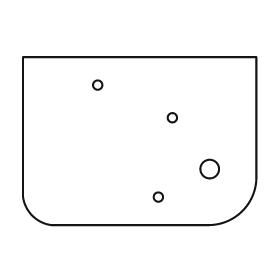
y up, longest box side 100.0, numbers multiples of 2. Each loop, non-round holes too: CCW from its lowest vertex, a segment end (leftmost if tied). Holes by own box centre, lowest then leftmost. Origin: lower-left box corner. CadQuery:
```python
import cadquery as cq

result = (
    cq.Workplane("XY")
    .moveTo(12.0, 0.0)
    .lineTo(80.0, 0.0)
    .threePointArc((94.0, 6.0), (100.0, 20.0))
    .lineTo(100.0, 72.0)
    .lineTo(0.0, 72.0)
    .lineTo(0.0, 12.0)
    .threePointArc((4.0, 4.0), (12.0, 0.0))
    .close()
    .moveTo(58.0, 12.0)
    .circle(2.0)
    .moveTo(80.0, 24.0)
    .circle(4.0)
    .moveTo(64.0, 46.0)
    .circle(2.0)
    .moveTo(32.0, 60.0)
    .circle(2.0)
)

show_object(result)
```